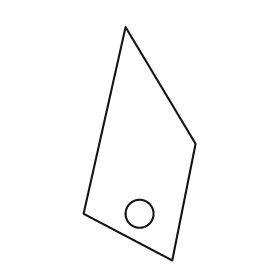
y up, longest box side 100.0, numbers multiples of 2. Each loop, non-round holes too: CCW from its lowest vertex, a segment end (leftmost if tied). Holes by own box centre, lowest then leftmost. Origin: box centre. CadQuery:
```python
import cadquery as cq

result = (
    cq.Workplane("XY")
    .moveTo(14.0, -50.0)
    .lineTo(24.0, 0.0)
    .lineTo(-6.0, 50.0)
    .lineTo(-24.0, -30.0)
    .close()
    .moveTo(0.0, -30.0)
    .circle(6.0)
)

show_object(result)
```